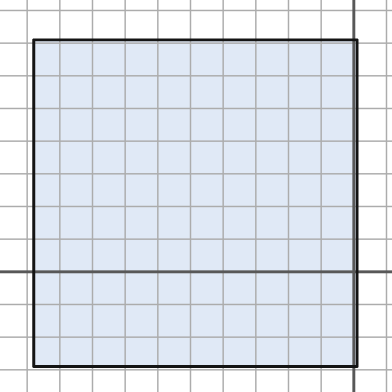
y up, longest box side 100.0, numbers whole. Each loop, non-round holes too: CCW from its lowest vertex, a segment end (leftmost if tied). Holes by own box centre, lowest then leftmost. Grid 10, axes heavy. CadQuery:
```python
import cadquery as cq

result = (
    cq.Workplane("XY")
    .moveTo(-98.0, -29.0)
    .lineTo(1.0, -29.0)
    .lineTo(1.0, 71.0)
    .lineTo(-98.0, 71.0)
    .close()
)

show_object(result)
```